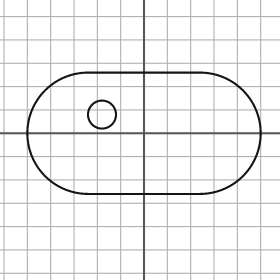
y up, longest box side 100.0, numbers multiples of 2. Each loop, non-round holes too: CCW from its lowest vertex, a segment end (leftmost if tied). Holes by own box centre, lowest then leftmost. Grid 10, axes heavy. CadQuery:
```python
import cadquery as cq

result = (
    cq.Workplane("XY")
    .moveTo(-24.0, -26.0)
    .lineTo(24.0, -26.0)
    .threePointArc((50.0, 0.0), (24.0, 26.0))
    .lineTo(-24.0, 26.0)
    .threePointArc((-50.0, 0.0), (-24.0, -26.0))
    .close()
    .moveTo(-18.0, 8.0)
    .circle(6.0)
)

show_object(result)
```